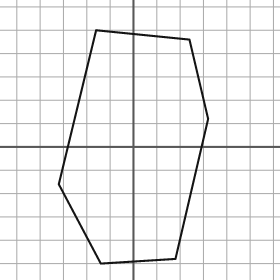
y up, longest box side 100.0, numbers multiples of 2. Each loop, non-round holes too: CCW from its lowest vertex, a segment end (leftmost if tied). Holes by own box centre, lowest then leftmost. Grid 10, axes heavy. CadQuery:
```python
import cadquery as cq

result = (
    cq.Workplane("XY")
    .moveTo(-14.0, -50.0)
    .lineTo(18.0, -48.0)
    .lineTo(32.0, 12.0)
    .lineTo(24.0, 46.0)
    .lineTo(-16.0, 50.0)
    .lineTo(-32.0, -16.0)
    .close()
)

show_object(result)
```